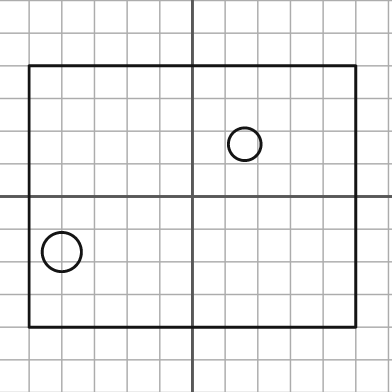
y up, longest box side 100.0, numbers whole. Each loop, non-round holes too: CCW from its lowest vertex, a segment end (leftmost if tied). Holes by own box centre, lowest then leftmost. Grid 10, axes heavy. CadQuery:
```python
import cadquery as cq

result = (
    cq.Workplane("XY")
    .moveTo(-50.0, -40.0)
    .lineTo(50.0, -40.0)
    .lineTo(50.0, 40.0)
    .lineTo(-50.0, 40.0)
    .close()
    .moveTo(-40.0, -17.0)
    .circle(6.0)
    .moveTo(16.0, 16.0)
    .circle(5.0)
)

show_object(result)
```